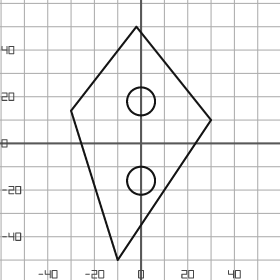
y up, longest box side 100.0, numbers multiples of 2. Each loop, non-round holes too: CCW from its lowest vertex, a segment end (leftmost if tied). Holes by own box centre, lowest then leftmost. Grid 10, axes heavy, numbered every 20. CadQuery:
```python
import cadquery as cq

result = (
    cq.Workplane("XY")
    .moveTo(-10.0, -50.0)
    .lineTo(30.0, 10.0)
    .lineTo(-2.0, 50.0)
    .lineTo(-30.0, 14.0)
    .close()
    .moveTo(0.0, -16.0)
    .circle(6.0)
    .moveTo(0.0, 18.0)
    .circle(6.0)
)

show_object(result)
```